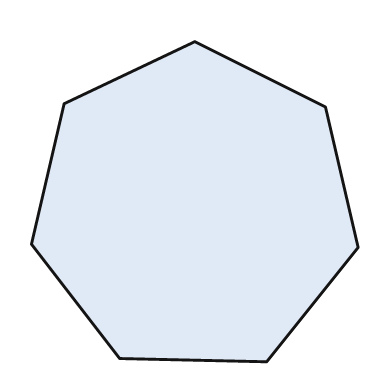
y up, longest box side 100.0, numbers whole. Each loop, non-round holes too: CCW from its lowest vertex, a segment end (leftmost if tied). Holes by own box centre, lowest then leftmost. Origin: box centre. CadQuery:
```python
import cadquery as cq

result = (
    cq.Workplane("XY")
    .moveTo(22.0, -49.0)
    .lineTo(50.0, -14.0)
    .lineTo(40.0, 29.0)
    .lineTo(0.0, 49.0)
    .lineTo(-40.0, 30.0)
    .lineTo(-50.0, -13.0)
    .lineTo(-23.0, -48.0)
    .close()
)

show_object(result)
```